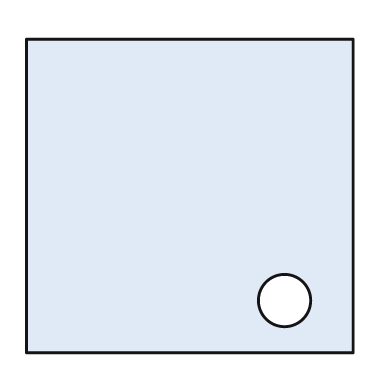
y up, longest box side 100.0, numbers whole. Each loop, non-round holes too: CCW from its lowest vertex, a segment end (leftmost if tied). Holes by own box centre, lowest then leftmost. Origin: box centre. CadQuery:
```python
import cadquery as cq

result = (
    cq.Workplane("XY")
    .moveTo(-50.0, -48.0)
    .lineTo(50.0, -48.0)
    .lineTo(50.0, 48.0)
    .lineTo(-50.0, 48.0)
    .close()
    .moveTo(29.0, -32.0)
    .circle(8.0)
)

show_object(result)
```